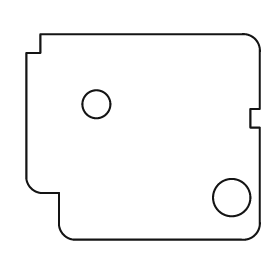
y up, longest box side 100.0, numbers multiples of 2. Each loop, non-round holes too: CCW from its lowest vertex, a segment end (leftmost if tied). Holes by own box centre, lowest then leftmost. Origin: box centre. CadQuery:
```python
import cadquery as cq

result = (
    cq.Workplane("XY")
    .moveTo(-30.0, -44.0)
    .lineTo(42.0, -44.0)
    .threePointArc((48.0, -42.0), (50.0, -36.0))
    .lineTo(50.0, 4.0)
    .lineTo(46.0, 4.0)
    .lineTo(46.0, 12.0)
    .lineTo(50.0, 12.0)
    .lineTo(50.0, 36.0)
    .threePointArc((48.0, 42.0), (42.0, 44.0))
    .lineTo(-44.0, 44.0)
    .lineTo(-44.0, 36.0)
    .lineTo(-50.0, 36.0)
    .lineTo(-50.0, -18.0)
    .threePointArc((-48.0, -22.0), (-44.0, -24.0))
    .lineTo(-36.0, -24.0)
    .lineTo(-36.0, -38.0)
    .threePointArc((-34.0, -42.0), (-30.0, -44.0))
    .close()
    .moveTo(38.0, -26.0)
    .circle(8.0)
    .moveTo(-20.0, 14.0)
    .circle(6.0)
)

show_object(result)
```